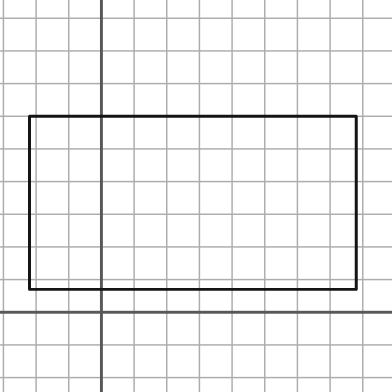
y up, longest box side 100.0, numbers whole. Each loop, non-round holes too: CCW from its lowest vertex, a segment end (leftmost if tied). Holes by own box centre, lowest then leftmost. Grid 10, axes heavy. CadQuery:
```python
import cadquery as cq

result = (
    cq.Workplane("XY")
    .moveTo(-22.0, 7.0)
    .lineTo(78.0, 7.0)
    .lineTo(78.0, 60.0)
    .lineTo(-22.0, 60.0)
    .close()
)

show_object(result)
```